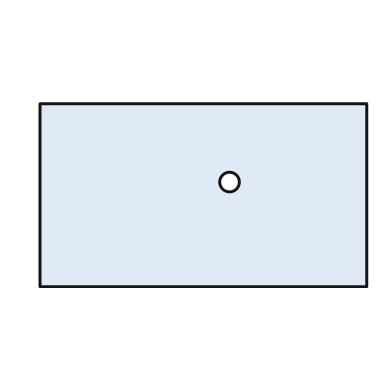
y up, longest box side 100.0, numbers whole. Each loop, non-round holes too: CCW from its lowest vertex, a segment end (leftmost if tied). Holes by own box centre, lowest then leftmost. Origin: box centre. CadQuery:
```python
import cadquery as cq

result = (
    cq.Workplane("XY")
    .moveTo(-50.0, -28.0)
    .lineTo(50.0, -28.0)
    .lineTo(50.0, 28.0)
    .lineTo(-50.0, 28.0)
    .close()
    .moveTo(8.0, 4.0)
    .circle(3.0)
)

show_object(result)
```